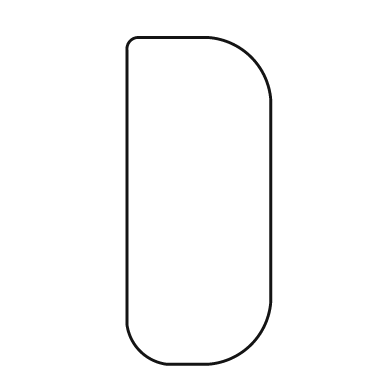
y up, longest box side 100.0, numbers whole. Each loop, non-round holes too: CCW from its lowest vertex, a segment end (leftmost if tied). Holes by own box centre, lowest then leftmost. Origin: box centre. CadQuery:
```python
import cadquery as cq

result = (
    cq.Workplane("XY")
    .moveTo(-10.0, -50.0)
    .lineTo(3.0, -50.0)
    .threePointArc((16.0, -44.0), (22.0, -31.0))
    .lineTo(22.0, 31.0)
    .threePointArc((16.0, 44.0), (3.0, 50.0))
    .lineTo(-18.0, 50.0)
    .threePointArc((-21.0, 49.0), (-22.0, 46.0))
    .lineTo(-22.0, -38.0)
    .threePointArc((-18.0, -46.0), (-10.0, -50.0))
    .close()
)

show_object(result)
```